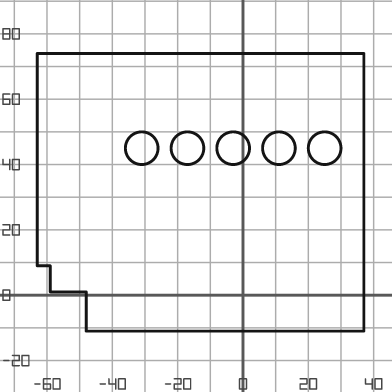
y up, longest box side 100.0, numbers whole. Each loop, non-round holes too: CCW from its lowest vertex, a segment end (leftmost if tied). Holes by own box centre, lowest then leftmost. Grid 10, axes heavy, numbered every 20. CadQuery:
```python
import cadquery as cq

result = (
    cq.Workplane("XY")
    .moveTo(-48.0, -11.0)
    .lineTo(37.0, -11.0)
    .lineTo(37.0, 74.0)
    .lineTo(-63.0, 74.0)
    .lineTo(-63.0, 9.0)
    .lineTo(-59.0, 9.0)
    .lineTo(-59.0, 1.0)
    .lineTo(-48.0, 1.0)
    .close()
    .moveTo(-31.0, 45.0)
    .circle(5.0)
    .moveTo(-17.0, 45.0)
    .circle(5.0)
    .moveTo(-3.0, 45.0)
    .circle(5.0)
    .moveTo(11.0, 45.0)
    .circle(5.0)
    .moveTo(25.0, 45.0)
    .circle(5.0)
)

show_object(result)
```